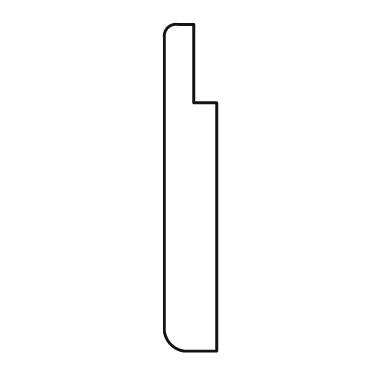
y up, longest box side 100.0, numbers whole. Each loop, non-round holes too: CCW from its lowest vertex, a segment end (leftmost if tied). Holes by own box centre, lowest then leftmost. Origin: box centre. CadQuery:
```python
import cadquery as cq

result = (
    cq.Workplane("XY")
    .moveTo(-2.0, -50.0)
    .lineTo(8.0, -50.0)
    .lineTo(8.0, 26.0)
    .lineTo(1.0, 26.0)
    .lineTo(1.0, 50.0)
    .lineTo(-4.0, 50.0)
    .threePointArc((-7.0, 49.0), (-8.0, 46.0))
    .lineTo(-8.0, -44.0)
    .threePointArc((-6.0, -48.0), (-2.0, -50.0))
    .close()
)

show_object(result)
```